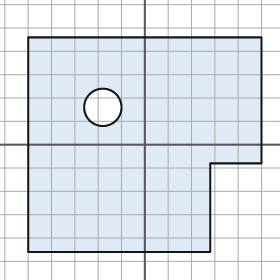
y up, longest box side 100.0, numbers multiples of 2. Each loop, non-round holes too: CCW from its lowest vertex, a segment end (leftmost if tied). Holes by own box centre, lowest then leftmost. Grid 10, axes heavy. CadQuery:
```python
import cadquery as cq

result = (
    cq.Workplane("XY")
    .moveTo(-50.0, -46.0)
    .lineTo(28.0, -46.0)
    .lineTo(28.0, -8.0)
    .lineTo(50.0, -8.0)
    .lineTo(50.0, 46.0)
    .lineTo(-50.0, 46.0)
    .close()
    .moveTo(-18.0, 16.0)
    .circle(8.0)
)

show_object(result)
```